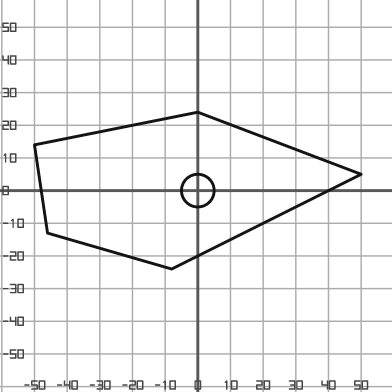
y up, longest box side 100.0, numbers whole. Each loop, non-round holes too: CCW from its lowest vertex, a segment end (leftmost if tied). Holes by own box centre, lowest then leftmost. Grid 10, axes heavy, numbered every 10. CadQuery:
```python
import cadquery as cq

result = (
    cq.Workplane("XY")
    .moveTo(-8.0, -24.0)
    .lineTo(50.0, 5.0)
    .lineTo(0.0, 24.0)
    .lineTo(-50.0, 14.0)
    .lineTo(-46.0, -13.0)
    .close()
    .moveTo(0.0, 0.0)
    .circle(5.0)
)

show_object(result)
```